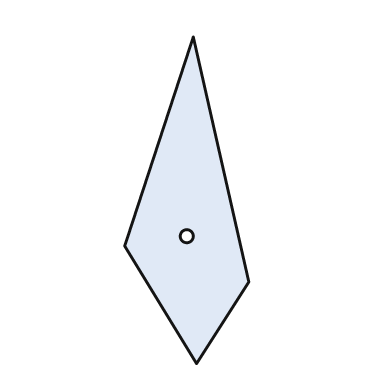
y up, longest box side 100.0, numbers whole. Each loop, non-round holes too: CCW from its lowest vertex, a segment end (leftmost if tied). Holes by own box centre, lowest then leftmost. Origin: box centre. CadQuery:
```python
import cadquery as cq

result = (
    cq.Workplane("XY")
    .moveTo(3.0, -50.0)
    .lineTo(19.0, -25.0)
    .lineTo(2.0, 50.0)
    .lineTo(-19.0, -14.0)
    .close()
    .moveTo(0.0, -11.0)
    .circle(2.0)
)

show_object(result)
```